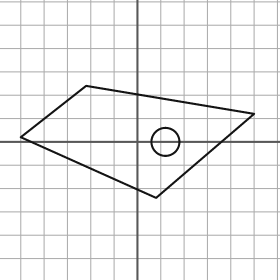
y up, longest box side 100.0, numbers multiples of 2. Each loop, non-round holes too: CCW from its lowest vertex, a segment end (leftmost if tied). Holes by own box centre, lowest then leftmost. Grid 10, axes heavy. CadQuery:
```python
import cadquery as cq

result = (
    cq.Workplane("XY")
    .moveTo(8.0, -24.0)
    .lineTo(50.0, 12.0)
    .lineTo(-22.0, 24.0)
    .lineTo(-50.0, 2.0)
    .close()
    .moveTo(12.0, 0.0)
    .circle(6.0)
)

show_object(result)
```